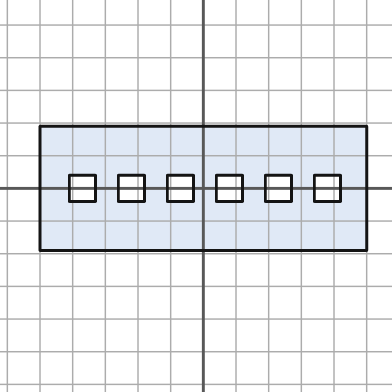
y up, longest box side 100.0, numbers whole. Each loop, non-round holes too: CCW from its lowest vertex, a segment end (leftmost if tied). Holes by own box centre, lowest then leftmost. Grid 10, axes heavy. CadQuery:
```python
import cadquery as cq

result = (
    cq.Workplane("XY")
    .moveTo(-50.0, -19.0)
    .lineTo(50.0, -19.0)
    .lineTo(50.0, 19.0)
    .lineTo(-50.0, 19.0)
    .close()
    .moveTo(-41.0, -4.0)
    .lineTo(-33.0, -4.0)
    .lineTo(-33.0, 4.0)
    .lineTo(-41.0, 4.0)
    .close()
    .moveTo(-26.0, -4.0)
    .lineTo(-18.0, -4.0)
    .lineTo(-18.0, 4.0)
    .lineTo(-26.0, 4.0)
    .close()
    .moveTo(-11.0, -4.0)
    .lineTo(-3.0, -4.0)
    .lineTo(-3.0, 4.0)
    .lineTo(-11.0, 4.0)
    .close()
    .moveTo(4.0, -4.0)
    .lineTo(12.0, -4.0)
    .lineTo(12.0, 4.0)
    .lineTo(4.0, 4.0)
    .close()
    .moveTo(19.0, -4.0)
    .lineTo(27.0, -4.0)
    .lineTo(27.0, 4.0)
    .lineTo(19.0, 4.0)
    .close()
    .moveTo(34.0, -4.0)
    .lineTo(42.0, -4.0)
    .lineTo(42.0, 4.0)
    .lineTo(34.0, 4.0)
    .close()
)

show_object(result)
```